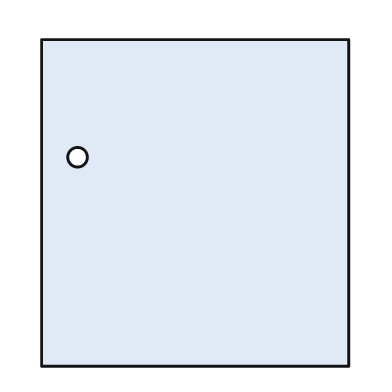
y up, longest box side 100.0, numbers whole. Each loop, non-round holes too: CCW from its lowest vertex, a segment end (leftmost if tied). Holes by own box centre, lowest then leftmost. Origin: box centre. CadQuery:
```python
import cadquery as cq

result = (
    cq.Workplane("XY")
    .moveTo(-47.0, -50.0)
    .lineTo(47.0, -50.0)
    .lineTo(47.0, 50.0)
    .lineTo(-47.0, 50.0)
    .close()
    .moveTo(-36.0, 14.0)
    .circle(3.0)
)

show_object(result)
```